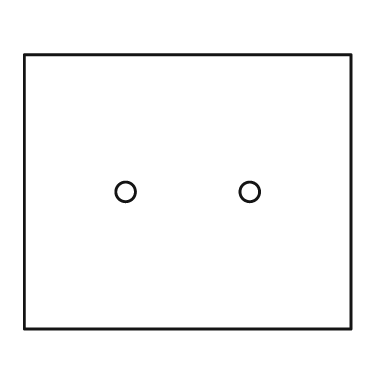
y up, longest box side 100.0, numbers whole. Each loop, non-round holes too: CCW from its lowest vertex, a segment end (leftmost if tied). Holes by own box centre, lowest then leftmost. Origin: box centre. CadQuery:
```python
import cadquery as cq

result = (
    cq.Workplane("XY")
    .moveTo(-50.0, -42.0)
    .lineTo(50.0, -42.0)
    .lineTo(50.0, 42.0)
    .lineTo(-50.0, 42.0)
    .close()
    .moveTo(-19.0, 0.0)
    .circle(3.0)
    .moveTo(19.0, 0.0)
    .circle(3.0)
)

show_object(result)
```